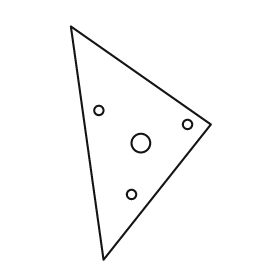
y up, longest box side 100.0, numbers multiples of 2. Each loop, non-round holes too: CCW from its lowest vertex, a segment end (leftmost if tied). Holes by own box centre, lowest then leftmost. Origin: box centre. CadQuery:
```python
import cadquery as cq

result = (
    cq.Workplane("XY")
    .moveTo(-16.0, -50.0)
    .lineTo(30.0, 8.0)
    .lineTo(-30.0, 50.0)
    .close()
    .moveTo(-4.0, -22.0)
    .circle(2.0)
    .moveTo(0.0, 0.0)
    .circle(4.0)
    .moveTo(20.0, 8.0)
    .circle(2.0)
    .moveTo(-18.0, 14.0)
    .circle(2.0)
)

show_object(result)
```